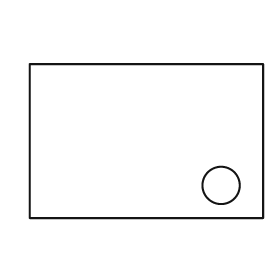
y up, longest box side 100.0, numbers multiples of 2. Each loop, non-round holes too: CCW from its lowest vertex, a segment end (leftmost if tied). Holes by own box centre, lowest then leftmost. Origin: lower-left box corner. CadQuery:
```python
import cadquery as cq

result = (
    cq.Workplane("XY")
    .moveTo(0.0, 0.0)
    .lineTo(100.0, 0.0)
    .lineTo(100.0, 66.0)
    .lineTo(0.0, 66.0)
    .close()
    .moveTo(82.0, 14.0)
    .circle(8.0)
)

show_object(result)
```